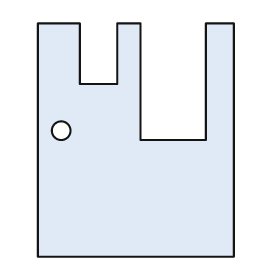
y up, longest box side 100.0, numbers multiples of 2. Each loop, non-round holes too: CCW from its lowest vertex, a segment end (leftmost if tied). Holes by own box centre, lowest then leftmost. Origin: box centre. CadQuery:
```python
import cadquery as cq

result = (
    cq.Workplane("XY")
    .moveTo(-42.0, -50.0)
    .lineTo(42.0, -50.0)
    .lineTo(42.0, 50.0)
    .lineTo(30.0, 50.0)
    .lineTo(30.0, 0.0)
    .lineTo(2.0, 0.0)
    .lineTo(2.0, 50.0)
    .lineTo(-8.0, 50.0)
    .lineTo(-8.0, 24.0)
    .lineTo(-24.0, 24.0)
    .lineTo(-24.0, 50.0)
    .lineTo(-42.0, 50.0)
    .close()
    .moveTo(-32.0, 4.0)
    .circle(4.0)
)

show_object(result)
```